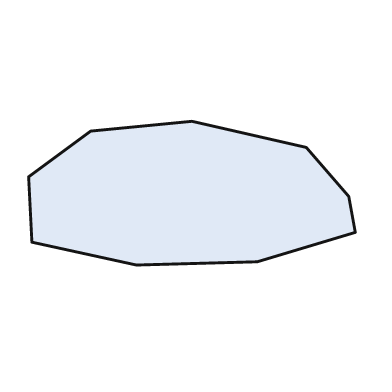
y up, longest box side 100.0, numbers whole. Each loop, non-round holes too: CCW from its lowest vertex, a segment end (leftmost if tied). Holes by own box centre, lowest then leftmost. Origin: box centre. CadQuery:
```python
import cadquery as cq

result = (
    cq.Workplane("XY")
    .moveTo(-17.0, -22.0)
    .lineTo(20.0, -21.0)
    .lineTo(50.0, -12.0)
    .lineTo(48.0, -1.0)
    .lineTo(35.0, 14.0)
    .lineTo(0.0, 22.0)
    .lineTo(-31.0, 19.0)
    .lineTo(-50.0, 5.0)
    .lineTo(-49.0, -15.0)
    .close()
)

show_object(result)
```